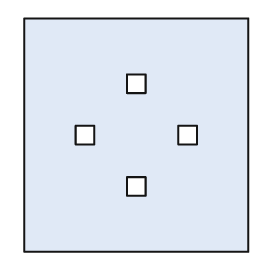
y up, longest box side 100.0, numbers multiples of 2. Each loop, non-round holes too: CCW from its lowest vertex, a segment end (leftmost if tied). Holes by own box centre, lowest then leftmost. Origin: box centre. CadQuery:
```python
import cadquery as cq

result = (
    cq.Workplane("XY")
    .moveTo(-48.0, -50.0)
    .lineTo(48.0, -50.0)
    .lineTo(48.0, 50.0)
    .lineTo(-48.0, 50.0)
    .close()
    .moveTo(-4.0, -26.0)
    .lineTo(4.0, -26.0)
    .lineTo(4.0, -18.0)
    .lineTo(-4.0, -18.0)
    .close()
    .moveTo(-26.0, -4.0)
    .lineTo(-18.0, -4.0)
    .lineTo(-18.0, 4.0)
    .lineTo(-26.0, 4.0)
    .close()
    .moveTo(18.0, -4.0)
    .lineTo(26.0, -4.0)
    .lineTo(26.0, 4.0)
    .lineTo(18.0, 4.0)
    .close()
    .moveTo(-4.0, 18.0)
    .lineTo(4.0, 18.0)
    .lineTo(4.0, 26.0)
    .lineTo(-4.0, 26.0)
    .close()
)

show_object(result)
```